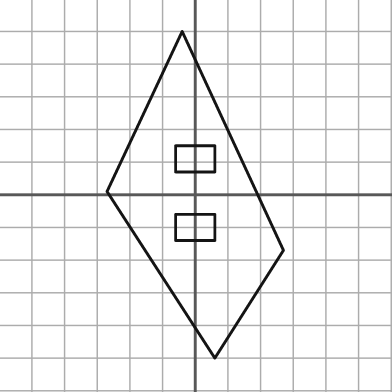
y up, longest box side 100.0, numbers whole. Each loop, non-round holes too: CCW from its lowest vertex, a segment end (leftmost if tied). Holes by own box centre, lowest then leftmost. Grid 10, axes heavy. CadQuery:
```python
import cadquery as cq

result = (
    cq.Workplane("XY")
    .moveTo(6.0, -50.0)
    .lineTo(27.0, -17.0)
    .lineTo(-4.0, 50.0)
    .lineTo(-27.0, 1.0)
    .close()
    .moveTo(-6.0, -14.0)
    .lineTo(6.0, -14.0)
    .lineTo(6.0, -6.0)
    .lineTo(-6.0, -6.0)
    .close()
    .moveTo(-6.0, 7.0)
    .lineTo(6.0, 7.0)
    .lineTo(6.0, 15.0)
    .lineTo(-6.0, 15.0)
    .close()
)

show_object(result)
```